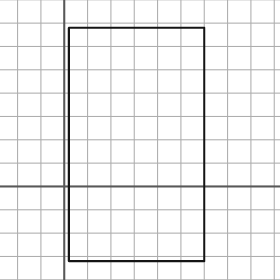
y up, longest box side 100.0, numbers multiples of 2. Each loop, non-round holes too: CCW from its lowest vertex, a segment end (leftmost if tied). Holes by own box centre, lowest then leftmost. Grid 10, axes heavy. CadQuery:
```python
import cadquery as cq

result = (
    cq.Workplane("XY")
    .moveTo(2.0, -32.0)
    .lineTo(60.0, -32.0)
    .lineTo(60.0, 68.0)
    .lineTo(2.0, 68.0)
    .close()
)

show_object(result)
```